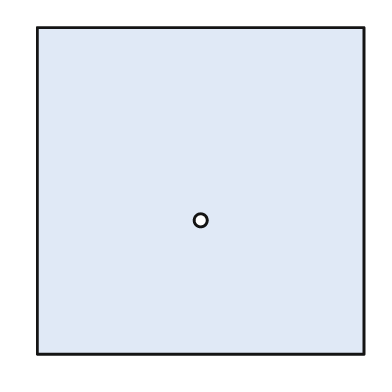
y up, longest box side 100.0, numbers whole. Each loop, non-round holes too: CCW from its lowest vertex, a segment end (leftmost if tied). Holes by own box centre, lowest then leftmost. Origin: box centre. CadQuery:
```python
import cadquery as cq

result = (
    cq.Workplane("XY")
    .moveTo(-50.0, -50.0)
    .lineTo(50.0, -50.0)
    .lineTo(50.0, 50.0)
    .lineTo(-50.0, 50.0)
    .close()
    .moveTo(0.0, -9.0)
    .circle(2.0)
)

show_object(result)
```